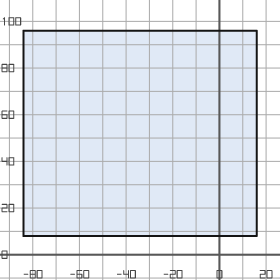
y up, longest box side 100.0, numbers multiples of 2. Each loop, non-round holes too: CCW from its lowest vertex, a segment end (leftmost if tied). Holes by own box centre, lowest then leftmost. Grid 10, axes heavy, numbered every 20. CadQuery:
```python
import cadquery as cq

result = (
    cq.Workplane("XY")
    .moveTo(-84.0, 8.0)
    .lineTo(16.0, 8.0)
    .lineTo(16.0, 96.0)
    .lineTo(-84.0, 96.0)
    .close()
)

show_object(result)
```